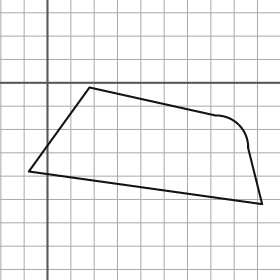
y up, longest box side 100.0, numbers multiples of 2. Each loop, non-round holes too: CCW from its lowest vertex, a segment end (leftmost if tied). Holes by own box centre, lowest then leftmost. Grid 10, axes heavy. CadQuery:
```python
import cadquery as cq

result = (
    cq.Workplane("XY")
    .moveTo(92.0, -52.0)
    .lineTo(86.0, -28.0)
    .threePointArc((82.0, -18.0), (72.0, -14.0))
    .lineTo(18.0, -2.0)
    .lineTo(-8.0, -38.0)
    .close()
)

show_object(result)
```